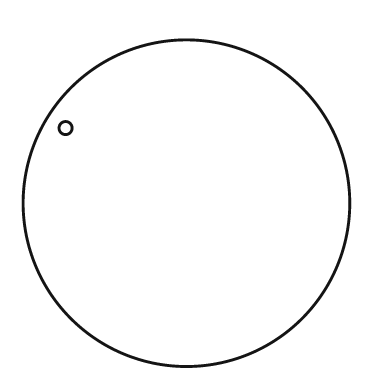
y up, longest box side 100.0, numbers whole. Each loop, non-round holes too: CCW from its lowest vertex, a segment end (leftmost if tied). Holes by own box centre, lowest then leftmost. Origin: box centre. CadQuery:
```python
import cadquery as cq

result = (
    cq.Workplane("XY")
    .moveTo(0.0, 0.0)
    .circle(50.0)
    .moveTo(-37.0, 23.0)
    .circle(2.0)
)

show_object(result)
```